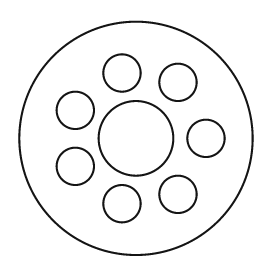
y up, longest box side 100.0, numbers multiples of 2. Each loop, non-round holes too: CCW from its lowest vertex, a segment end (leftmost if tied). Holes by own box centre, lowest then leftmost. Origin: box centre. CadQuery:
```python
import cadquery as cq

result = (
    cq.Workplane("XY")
    .moveTo(0.0, 0.0)
    .circle(50.0)
    .moveTo(-6.0, -28.0)
    .circle(8.0)
    .moveTo(18.0, -24.0)
    .circle(8.0)
    .moveTo(-26.0, -12.0)
    .circle(8.0)
    .moveTo(0.0, 0.0)
    .circle(16.0)
    .moveTo(30.0, 0.0)
    .circle(8.0)
    .moveTo(-26.0, 12.0)
    .circle(8.0)
    .moveTo(18.0, 24.0)
    .circle(8.0)
    .moveTo(-6.0, 28.0)
    .circle(8.0)
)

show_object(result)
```